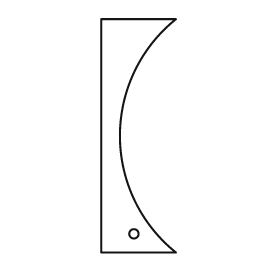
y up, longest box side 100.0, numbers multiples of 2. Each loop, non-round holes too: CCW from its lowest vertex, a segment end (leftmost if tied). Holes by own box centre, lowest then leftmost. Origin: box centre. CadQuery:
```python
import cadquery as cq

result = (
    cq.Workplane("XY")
    .moveTo(-16.0, -50.0)
    .lineTo(16.0, -50.0)
    .threePointArc((-8.0, 0.0), (16.0, 50.0))
    .lineTo(-16.0, 50.0)
    .close()
    .moveTo(-2.0, -42.0)
    .circle(2.0)
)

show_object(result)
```